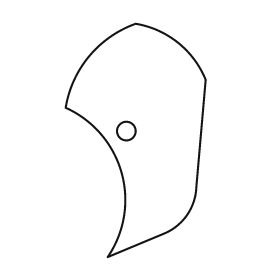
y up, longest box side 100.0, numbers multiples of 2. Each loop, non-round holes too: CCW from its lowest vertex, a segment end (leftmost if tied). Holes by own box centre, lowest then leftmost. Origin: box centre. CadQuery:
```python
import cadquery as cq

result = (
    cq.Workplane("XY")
    .moveTo(-12.0, -50.0)
    .lineTo(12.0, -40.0)
    .threePointArc((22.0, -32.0), (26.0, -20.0))
    .lineTo(30.0, 26.0)
    .threePointArc((18.0, 42.0), (0.0, 50.0))
    .threePointArc((-20.0, 36.0), (-30.0, 14.0))
    .threePointArc((-6.0, -14.0), (-12.0, -50.0))
    .close()
    .moveTo(-4.0, 4.0)
    .circle(4.0)
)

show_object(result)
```